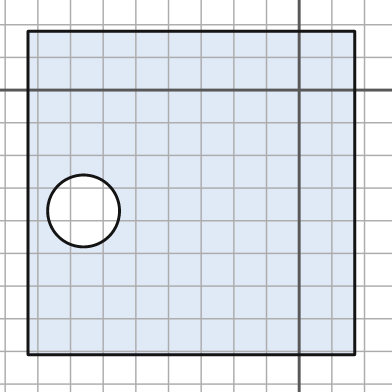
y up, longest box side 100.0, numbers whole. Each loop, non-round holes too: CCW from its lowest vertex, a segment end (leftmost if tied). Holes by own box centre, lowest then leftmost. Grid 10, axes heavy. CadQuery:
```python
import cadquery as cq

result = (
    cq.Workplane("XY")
    .moveTo(-83.0, -81.0)
    .lineTo(17.0, -81.0)
    .lineTo(17.0, 18.0)
    .lineTo(-83.0, 18.0)
    .close()
    .moveTo(-66.0, -37.0)
    .circle(11.0)
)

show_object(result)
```